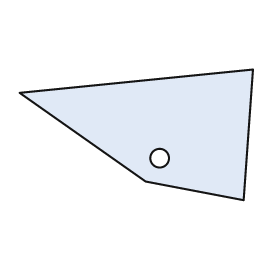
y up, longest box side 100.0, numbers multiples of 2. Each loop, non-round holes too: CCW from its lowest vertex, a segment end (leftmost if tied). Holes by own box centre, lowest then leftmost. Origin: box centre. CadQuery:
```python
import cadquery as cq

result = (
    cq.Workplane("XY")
    .moveTo(46.0, -28.0)
    .lineTo(50.0, 28.0)
    .lineTo(-50.0, 18.0)
    .lineTo(4.0, -20.0)
    .close()
    .moveTo(10.0, -10.0)
    .circle(4.0)
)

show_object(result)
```